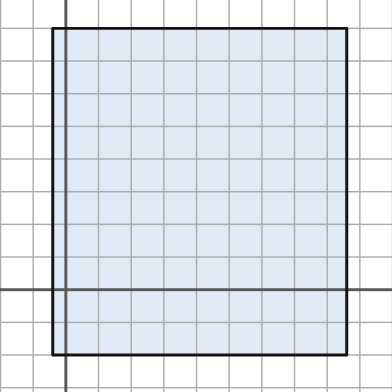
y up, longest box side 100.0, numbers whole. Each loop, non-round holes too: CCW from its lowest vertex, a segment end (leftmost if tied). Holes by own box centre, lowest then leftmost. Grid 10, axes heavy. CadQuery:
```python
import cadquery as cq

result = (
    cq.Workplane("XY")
    .moveTo(-4.0, -20.0)
    .lineTo(86.0, -20.0)
    .lineTo(86.0, 80.0)
    .lineTo(-4.0, 80.0)
    .close()
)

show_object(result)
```